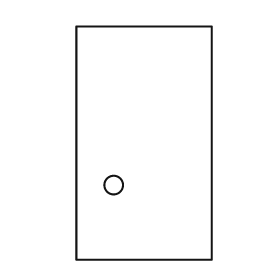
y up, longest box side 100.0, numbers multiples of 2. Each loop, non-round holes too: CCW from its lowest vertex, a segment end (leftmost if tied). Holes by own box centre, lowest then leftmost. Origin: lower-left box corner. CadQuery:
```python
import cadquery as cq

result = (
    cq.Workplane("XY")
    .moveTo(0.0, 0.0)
    .lineTo(58.0, 0.0)
    .lineTo(58.0, 100.0)
    .lineTo(0.0, 100.0)
    .close()
    .moveTo(16.0, 32.0)
    .circle(4.0)
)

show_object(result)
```